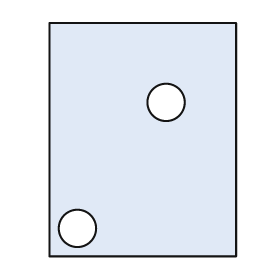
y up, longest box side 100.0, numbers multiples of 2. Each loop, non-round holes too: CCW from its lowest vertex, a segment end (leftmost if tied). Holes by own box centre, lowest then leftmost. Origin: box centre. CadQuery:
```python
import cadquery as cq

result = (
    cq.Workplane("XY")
    .moveTo(-40.0, -50.0)
    .lineTo(40.0, -50.0)
    .lineTo(40.0, 50.0)
    .lineTo(-40.0, 50.0)
    .close()
    .moveTo(-28.0, -38.0)
    .circle(8.0)
    .moveTo(10.0, 16.0)
    .circle(8.0)
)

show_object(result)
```